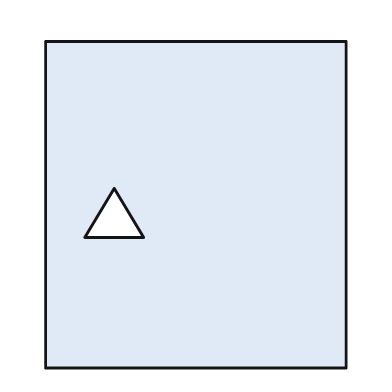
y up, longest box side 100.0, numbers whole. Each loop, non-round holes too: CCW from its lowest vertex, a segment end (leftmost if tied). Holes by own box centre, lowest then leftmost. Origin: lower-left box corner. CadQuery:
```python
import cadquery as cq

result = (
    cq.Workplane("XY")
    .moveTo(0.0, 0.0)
    .lineTo(92.0, 0.0)
    .lineTo(92.0, 100.0)
    .lineTo(0.0, 100.0)
    .close()
    .moveTo(12.0, 40.0)
    .lineTo(30.0, 40.0)
    .lineTo(21.0, 55.0)
    .close()
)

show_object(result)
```